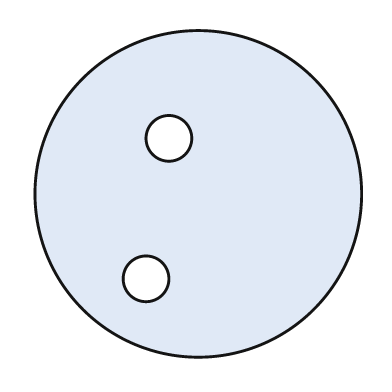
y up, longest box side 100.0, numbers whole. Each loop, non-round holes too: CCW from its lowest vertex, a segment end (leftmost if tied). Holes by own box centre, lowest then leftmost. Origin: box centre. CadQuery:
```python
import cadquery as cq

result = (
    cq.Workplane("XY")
    .moveTo(0.0, 0.0)
    .circle(50.0)
    .moveTo(-16.0, -26.0)
    .circle(7.0)
    .moveTo(-9.0, 17.0)
    .circle(7.0)
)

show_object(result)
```